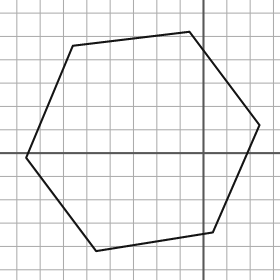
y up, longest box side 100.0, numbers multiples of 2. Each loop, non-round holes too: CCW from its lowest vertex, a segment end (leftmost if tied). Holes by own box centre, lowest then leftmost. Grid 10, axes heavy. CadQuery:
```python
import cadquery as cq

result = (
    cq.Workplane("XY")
    .moveTo(-46.0, -42.0)
    .lineTo(4.0, -34.0)
    .lineTo(24.0, 12.0)
    .lineTo(-6.0, 52.0)
    .lineTo(-56.0, 46.0)
    .lineTo(-76.0, -2.0)
    .close()
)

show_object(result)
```